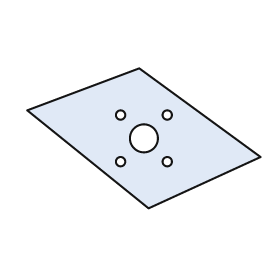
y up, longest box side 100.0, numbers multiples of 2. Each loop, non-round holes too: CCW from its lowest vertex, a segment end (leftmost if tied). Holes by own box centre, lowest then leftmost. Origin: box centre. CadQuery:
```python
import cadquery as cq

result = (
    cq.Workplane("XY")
    .moveTo(2.0, -30.0)
    .lineTo(50.0, -8.0)
    .lineTo(-2.0, 30.0)
    .lineTo(-50.0, 12.0)
    .close()
    .moveTo(-10.0, -10.0)
    .circle(2.0)
    .moveTo(10.0, -10.0)
    .circle(2.0)
    .moveTo(0.0, 0.0)
    .circle(6.0)
    .moveTo(-10.0, 10.0)
    .circle(2.0)
    .moveTo(10.0, 10.0)
    .circle(2.0)
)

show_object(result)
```